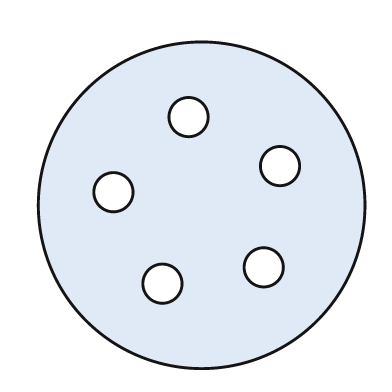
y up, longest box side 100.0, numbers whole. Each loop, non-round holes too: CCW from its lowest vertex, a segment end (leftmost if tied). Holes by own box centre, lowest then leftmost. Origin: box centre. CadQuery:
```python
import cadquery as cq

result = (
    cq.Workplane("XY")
    .moveTo(0.0, 0.0)
    .circle(50.0)
    .moveTo(-12.0, -24.0)
    .circle(6.0)
    .moveTo(19.0, -19.0)
    .circle(6.0)
    .moveTo(-27.0, 4.0)
    .circle(6.0)
    .moveTo(24.0, 12.0)
    .circle(6.0)
    .moveTo(-4.0, 27.0)
    .circle(6.0)
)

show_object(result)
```